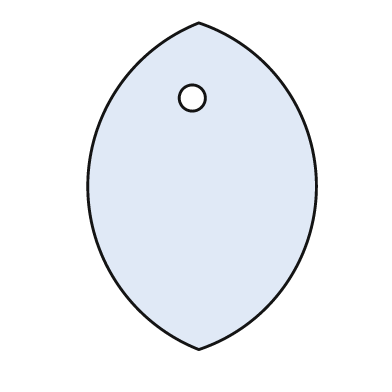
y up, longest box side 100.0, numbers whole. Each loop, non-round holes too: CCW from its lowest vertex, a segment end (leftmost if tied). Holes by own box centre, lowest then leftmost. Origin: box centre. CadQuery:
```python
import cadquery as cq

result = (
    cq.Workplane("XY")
    .moveTo(-1.0, -50.0)
    .threePointArc((35.0, 0.0), (-1.0, 50.0))
    .threePointArc((-35.0, 0.0), (-1.0, -50.0))
    .close()
    .moveTo(-3.0, 27.0)
    .circle(4.0)
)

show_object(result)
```